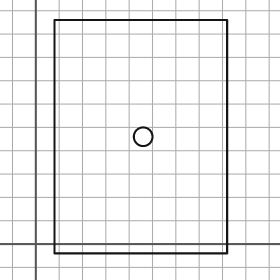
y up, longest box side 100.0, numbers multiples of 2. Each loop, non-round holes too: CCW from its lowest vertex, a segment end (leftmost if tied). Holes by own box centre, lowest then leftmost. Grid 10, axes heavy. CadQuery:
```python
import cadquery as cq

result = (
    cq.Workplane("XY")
    .moveTo(8.0, -4.0)
    .lineTo(82.0, -4.0)
    .lineTo(82.0, 96.0)
    .lineTo(8.0, 96.0)
    .close()
    .moveTo(46.0, 46.0)
    .circle(4.0)
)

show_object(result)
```